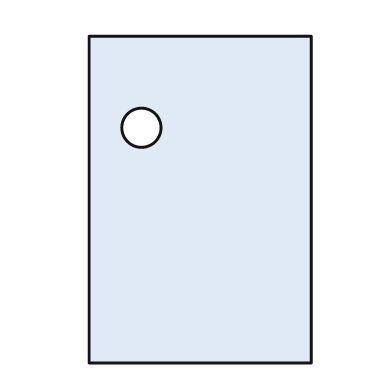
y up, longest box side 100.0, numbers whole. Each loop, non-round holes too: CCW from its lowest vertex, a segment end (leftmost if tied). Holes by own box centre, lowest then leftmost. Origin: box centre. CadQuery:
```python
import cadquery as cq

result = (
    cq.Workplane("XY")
    .moveTo(-34.0, -50.0)
    .lineTo(34.0, -50.0)
    .lineTo(34.0, 50.0)
    .lineTo(-34.0, 50.0)
    .close()
    .moveTo(-18.0, 22.0)
    .circle(6.0)
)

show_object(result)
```